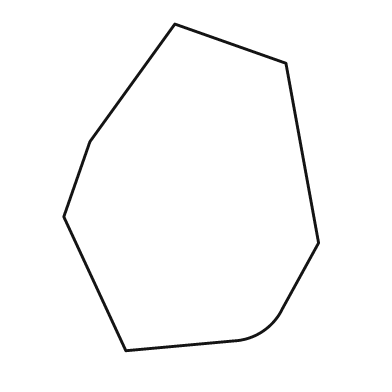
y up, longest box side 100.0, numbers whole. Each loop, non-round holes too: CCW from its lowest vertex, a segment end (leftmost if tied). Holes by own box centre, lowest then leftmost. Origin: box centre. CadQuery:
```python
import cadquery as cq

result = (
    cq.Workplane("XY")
    .moveTo(-20.0, -50.0)
    .lineTo(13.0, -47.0)
    .threePointArc((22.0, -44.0), (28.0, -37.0))
    .lineTo(39.0, -17.0)
    .lineTo(29.0, 38.0)
    .lineTo(-5.0, 50.0)
    .lineTo(-31.0, 14.0)
    .lineTo(-39.0, -9.0)
    .close()
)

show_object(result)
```